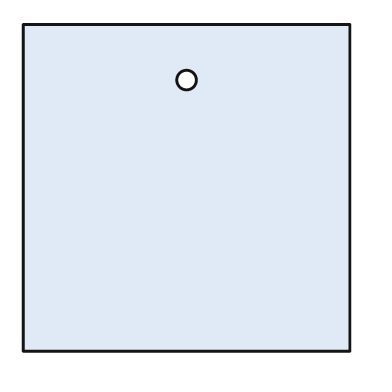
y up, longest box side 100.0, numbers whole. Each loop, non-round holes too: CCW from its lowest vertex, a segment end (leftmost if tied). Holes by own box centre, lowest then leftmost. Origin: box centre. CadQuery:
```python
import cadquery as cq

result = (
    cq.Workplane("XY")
    .moveTo(-50.0, -50.0)
    .lineTo(50.0, -50.0)
    .lineTo(50.0, 50.0)
    .lineTo(-50.0, 50.0)
    .close()
    .moveTo(0.0, 33.0)
    .circle(3.0)
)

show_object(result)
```